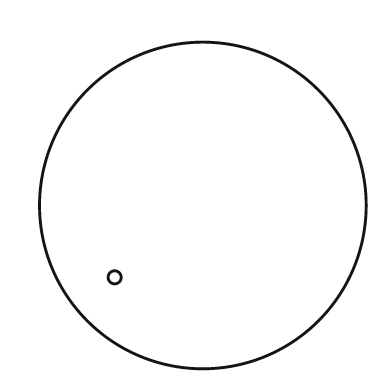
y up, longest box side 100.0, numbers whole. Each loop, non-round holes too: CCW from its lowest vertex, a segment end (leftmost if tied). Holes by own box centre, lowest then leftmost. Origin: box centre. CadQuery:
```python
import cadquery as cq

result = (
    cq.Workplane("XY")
    .moveTo(0.0, 0.0)
    .circle(50.0)
    .moveTo(-27.0, -22.0)
    .circle(2.0)
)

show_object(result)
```